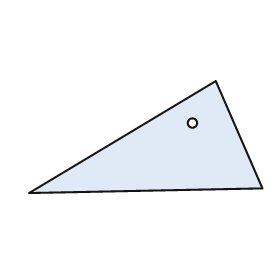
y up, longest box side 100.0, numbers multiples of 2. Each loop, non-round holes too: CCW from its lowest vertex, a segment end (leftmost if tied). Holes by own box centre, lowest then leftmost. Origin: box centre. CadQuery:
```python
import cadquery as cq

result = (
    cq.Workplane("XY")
    .moveTo(-50.0, -24.0)
    .lineTo(50.0, -22.0)
    .lineTo(30.0, 24.0)
    .close()
    .moveTo(20.0, 6.0)
    .circle(2.0)
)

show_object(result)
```